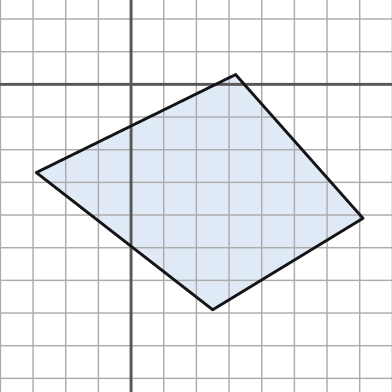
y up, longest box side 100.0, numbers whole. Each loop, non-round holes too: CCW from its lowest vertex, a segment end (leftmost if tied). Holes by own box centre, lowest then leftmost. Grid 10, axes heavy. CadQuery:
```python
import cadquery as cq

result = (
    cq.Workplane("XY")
    .moveTo(25.0, -69.0)
    .lineTo(71.0, -41.0)
    .lineTo(32.0, 3.0)
    .lineTo(-29.0, -27.0)
    .close()
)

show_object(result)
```